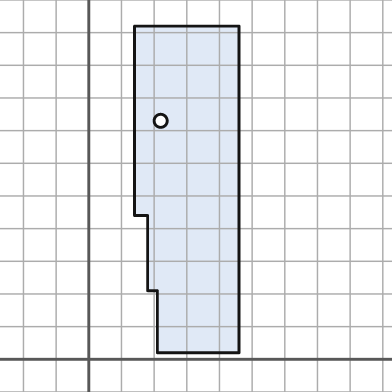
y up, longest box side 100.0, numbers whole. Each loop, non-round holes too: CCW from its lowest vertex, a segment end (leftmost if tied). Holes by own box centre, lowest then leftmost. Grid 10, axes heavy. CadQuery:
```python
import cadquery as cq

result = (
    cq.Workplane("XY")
    .moveTo(21.0, 2.0)
    .lineTo(46.0, 2.0)
    .lineTo(46.0, 102.0)
    .lineTo(14.0, 102.0)
    .lineTo(14.0, 44.0)
    .lineTo(18.0, 44.0)
    .lineTo(18.0, 21.0)
    .lineTo(21.0, 21.0)
    .close()
    .moveTo(22.0, 73.0)
    .circle(2.0)
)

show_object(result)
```